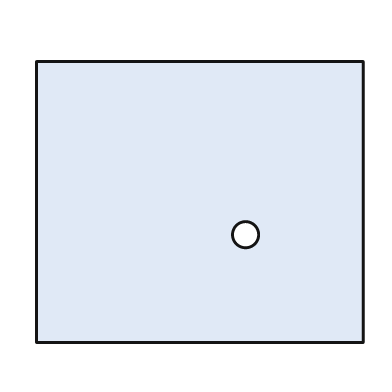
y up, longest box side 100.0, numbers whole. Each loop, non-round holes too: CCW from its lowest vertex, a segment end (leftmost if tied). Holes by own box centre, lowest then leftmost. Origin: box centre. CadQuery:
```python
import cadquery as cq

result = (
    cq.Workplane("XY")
    .moveTo(-50.0, -43.0)
    .lineTo(50.0, -43.0)
    .lineTo(50.0, 43.0)
    .lineTo(-50.0, 43.0)
    .close()
    .moveTo(14.0, -10.0)
    .circle(4.0)
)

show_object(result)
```